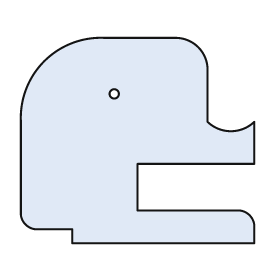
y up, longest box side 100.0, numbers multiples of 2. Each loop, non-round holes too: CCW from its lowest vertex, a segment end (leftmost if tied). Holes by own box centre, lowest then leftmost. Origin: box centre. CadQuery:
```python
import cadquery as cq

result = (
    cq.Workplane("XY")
    .moveTo(-28.0, -44.0)
    .lineTo(50.0, -44.0)
    .lineTo(50.0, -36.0)
    .threePointArc((48.0, -32.0), (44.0, -30.0))
    .lineTo(0.0, -30.0)
    .lineTo(0.0, -10.0)
    .lineTo(50.0, -10.0)
    .lineTo(50.0, 8.0)
    .threePointArc((40.0, 4.0), (30.0, 8.0))
    .lineTo(30.0, 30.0)
    .threePointArc((26.0, 40.0), (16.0, 44.0))
    .lineTo(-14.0, 44.0)
    .threePointArc((-40.0, 34.0), (-50.0, 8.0))
    .lineTo(-50.0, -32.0)
    .threePointArc((-48.0, -36.0), (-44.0, -38.0))
    .lineTo(-28.0, -38.0)
    .close()
    .moveTo(-10.0, 20.0)
    .circle(2.0)
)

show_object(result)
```